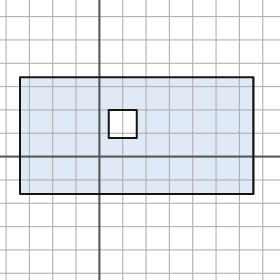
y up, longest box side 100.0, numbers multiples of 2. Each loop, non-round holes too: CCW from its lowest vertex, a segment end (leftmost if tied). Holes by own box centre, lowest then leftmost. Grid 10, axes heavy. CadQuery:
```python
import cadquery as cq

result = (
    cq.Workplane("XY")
    .moveTo(-34.0, -16.0)
    .lineTo(66.0, -16.0)
    .lineTo(66.0, 34.0)
    .lineTo(-34.0, 34.0)
    .close()
    .moveTo(4.0, 8.0)
    .lineTo(16.0, 8.0)
    .lineTo(16.0, 20.0)
    .lineTo(4.0, 20.0)
    .close()
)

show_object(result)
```